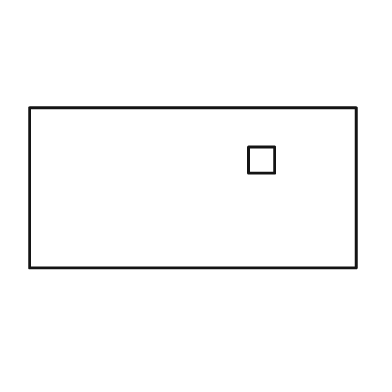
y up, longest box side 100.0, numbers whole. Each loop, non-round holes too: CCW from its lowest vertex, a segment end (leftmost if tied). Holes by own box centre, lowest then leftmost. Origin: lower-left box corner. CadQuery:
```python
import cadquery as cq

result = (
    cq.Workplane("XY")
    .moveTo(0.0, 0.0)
    .lineTo(100.0, 0.0)
    .lineTo(100.0, 49.0)
    .lineTo(0.0, 49.0)
    .close()
    .moveTo(67.0, 29.0)
    .lineTo(75.0, 29.0)
    .lineTo(75.0, 37.0)
    .lineTo(67.0, 37.0)
    .close()
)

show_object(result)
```